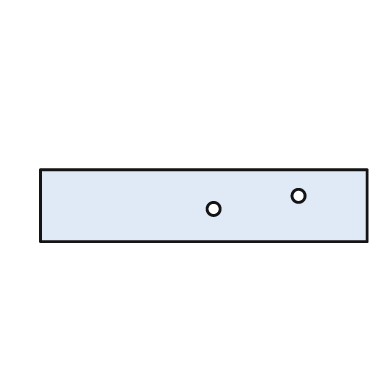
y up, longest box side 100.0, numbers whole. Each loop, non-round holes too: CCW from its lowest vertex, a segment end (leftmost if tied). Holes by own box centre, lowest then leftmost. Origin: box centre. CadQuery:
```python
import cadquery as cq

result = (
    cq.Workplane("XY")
    .moveTo(-50.0, -11.0)
    .lineTo(50.0, -11.0)
    .lineTo(50.0, 11.0)
    .lineTo(-50.0, 11.0)
    .close()
    .moveTo(3.0, -1.0)
    .circle(2.0)
    .moveTo(29.0, 3.0)
    .circle(2.0)
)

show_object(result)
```